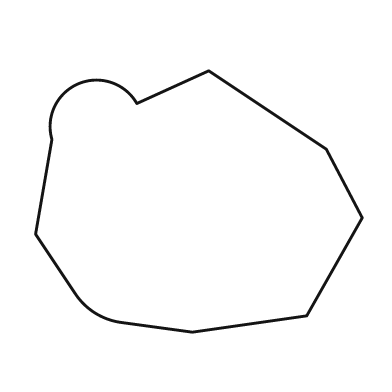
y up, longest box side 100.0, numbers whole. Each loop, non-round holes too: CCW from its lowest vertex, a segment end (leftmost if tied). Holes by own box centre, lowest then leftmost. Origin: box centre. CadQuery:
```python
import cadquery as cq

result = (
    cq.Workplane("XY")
    .moveTo(-2.0, -40.0)
    .lineTo(33.0, -35.0)
    .lineTo(50.0, -5.0)
    .lineTo(39.0, 16.0)
    .lineTo(3.0, 40.0)
    .lineTo(-19.0, 30.0)
    .threePointArc((-37.0, 36.0), (-45.0, 19.0))
    .lineTo(-50.0, -10.0)
    .lineTo(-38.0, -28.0)
    .threePointArc((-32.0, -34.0), (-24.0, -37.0))
    .close()
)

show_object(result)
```